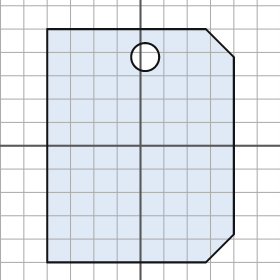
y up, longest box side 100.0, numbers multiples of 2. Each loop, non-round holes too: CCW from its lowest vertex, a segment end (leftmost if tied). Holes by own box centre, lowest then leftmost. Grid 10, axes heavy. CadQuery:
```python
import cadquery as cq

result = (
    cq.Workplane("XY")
    .moveTo(-40.0, -50.0)
    .lineTo(28.0, -50.0)
    .lineTo(40.0, -38.0)
    .lineTo(40.0, 38.0)
    .lineTo(28.0, 50.0)
    .lineTo(-40.0, 50.0)
    .close()
    .moveTo(2.0, 38.0)
    .circle(6.0)
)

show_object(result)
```